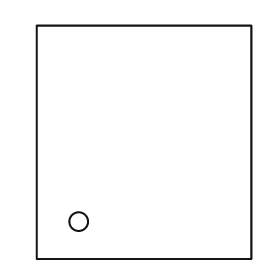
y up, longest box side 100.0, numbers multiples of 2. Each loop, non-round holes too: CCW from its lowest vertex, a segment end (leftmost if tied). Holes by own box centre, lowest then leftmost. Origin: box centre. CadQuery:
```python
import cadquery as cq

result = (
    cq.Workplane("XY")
    .moveTo(-46.0, -50.0)
    .lineTo(46.0, -50.0)
    .lineTo(46.0, 50.0)
    .lineTo(-46.0, 50.0)
    .close()
    .moveTo(-28.0, -34.0)
    .circle(4.0)
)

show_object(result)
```